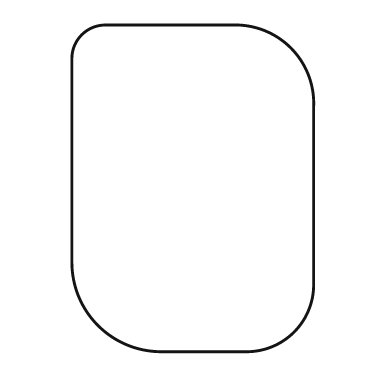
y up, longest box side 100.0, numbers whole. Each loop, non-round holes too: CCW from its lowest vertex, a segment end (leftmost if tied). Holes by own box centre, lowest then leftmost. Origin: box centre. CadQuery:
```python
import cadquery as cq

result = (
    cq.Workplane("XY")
    .moveTo(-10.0, -50.0)
    .lineTo(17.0, -50.0)
    .threePointArc((31.0, -44.0), (37.0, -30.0))
    .lineTo(37.0, 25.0)
    .threePointArc((30.0, 43.0), (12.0, 50.0))
    .lineTo(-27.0, 50.0)
    .threePointArc((-34.0, 47.0), (-37.0, 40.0))
    .lineTo(-37.0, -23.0)
    .threePointArc((-29.0, -42.0), (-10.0, -50.0))
    .close()
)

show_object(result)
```